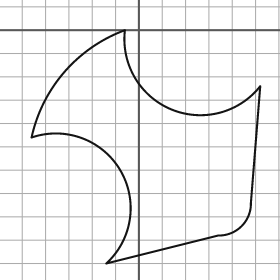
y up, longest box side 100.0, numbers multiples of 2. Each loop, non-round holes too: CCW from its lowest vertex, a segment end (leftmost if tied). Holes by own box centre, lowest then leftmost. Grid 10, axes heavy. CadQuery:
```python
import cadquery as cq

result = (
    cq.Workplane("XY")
    .moveTo(-14.0, -100.0)
    .lineTo(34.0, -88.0)
    .threePointArc((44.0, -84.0), (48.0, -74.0))
    .lineTo(52.0, -24.0)
    .threePointArc((14.0, -34.0), (-6.0, 0.0))
    .threePointArc((-32.0, -18.0), (-46.0, -46.0))
    .threePointArc((-8.0, -60.0), (-14.0, -100.0))
    .close()
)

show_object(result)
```